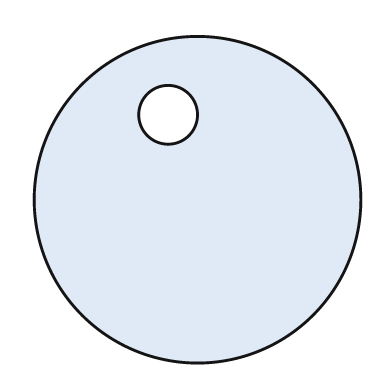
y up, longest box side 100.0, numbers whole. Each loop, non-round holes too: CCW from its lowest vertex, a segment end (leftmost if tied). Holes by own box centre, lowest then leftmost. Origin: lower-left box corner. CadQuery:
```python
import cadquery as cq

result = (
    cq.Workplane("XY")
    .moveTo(50.0, 50.0)
    .circle(50.0)
    .moveTo(41.0, 76.0)
    .circle(9.0)
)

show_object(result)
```